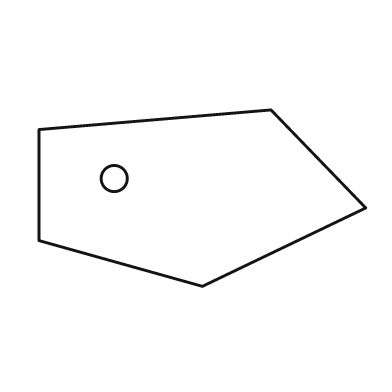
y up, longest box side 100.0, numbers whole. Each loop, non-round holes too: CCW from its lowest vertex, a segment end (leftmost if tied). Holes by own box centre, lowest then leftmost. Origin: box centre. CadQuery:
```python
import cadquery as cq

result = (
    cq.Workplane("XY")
    .moveTo(0.0, -27.0)
    .lineTo(50.0, -3.0)
    .lineTo(21.0, 27.0)
    .lineTo(-50.0, 21.0)
    .lineTo(-50.0, -13.0)
    .close()
    .moveTo(-27.0, 6.0)
    .circle(4.0)
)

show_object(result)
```